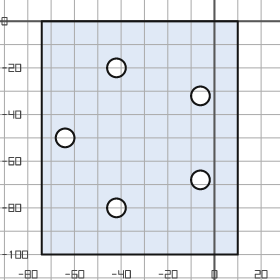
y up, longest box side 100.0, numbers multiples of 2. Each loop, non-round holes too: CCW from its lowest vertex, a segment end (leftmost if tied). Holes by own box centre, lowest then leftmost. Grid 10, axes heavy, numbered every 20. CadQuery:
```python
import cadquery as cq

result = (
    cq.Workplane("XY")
    .moveTo(-74.0, -100.0)
    .lineTo(10.0, -100.0)
    .lineTo(10.0, 0.0)
    .lineTo(-74.0, 0.0)
    .close()
    .moveTo(-42.0, -80.0)
    .circle(4.0)
    .moveTo(-6.0, -68.0)
    .circle(4.0)
    .moveTo(-64.0, -50.0)
    .circle(4.0)
    .moveTo(-6.0, -32.0)
    .circle(4.0)
    .moveTo(-42.0, -20.0)
    .circle(4.0)
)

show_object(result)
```